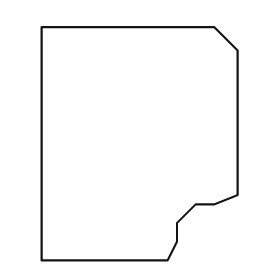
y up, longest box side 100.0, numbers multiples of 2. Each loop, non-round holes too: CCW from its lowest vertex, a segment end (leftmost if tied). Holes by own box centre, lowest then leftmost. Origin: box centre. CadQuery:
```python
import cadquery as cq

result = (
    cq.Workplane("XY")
    .moveTo(-42.0, -50.0)
    .lineTo(12.0, -50.0)
    .lineTo(16.0, -42.0)
    .lineTo(16.0, -34.0)
    .lineTo(24.0, -26.0)
    .lineTo(32.0, -26.0)
    .lineTo(42.0, -22.0)
    .lineTo(42.0, 40.0)
    .lineTo(32.0, 50.0)
    .lineTo(-42.0, 50.0)
    .close()
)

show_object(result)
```